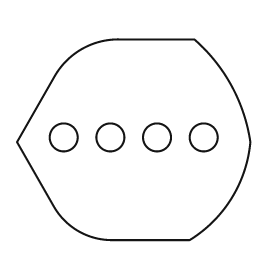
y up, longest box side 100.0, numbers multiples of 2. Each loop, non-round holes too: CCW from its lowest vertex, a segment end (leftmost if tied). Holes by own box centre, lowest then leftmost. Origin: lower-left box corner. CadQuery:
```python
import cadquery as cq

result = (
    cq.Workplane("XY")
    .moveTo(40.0, 0.0)
    .lineTo(74.0, 0.0)
    .threePointArc((92.0, 18.0), (100.0, 42.0))
    .threePointArc((92.0, 66.0), (76.0, 86.0))
    .lineTo(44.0, 86.0)
    .threePointArc((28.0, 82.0), (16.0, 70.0))
    .lineTo(0.0, 42.0)
    .lineTo(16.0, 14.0)
    .threePointArc((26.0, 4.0), (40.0, 0.0))
    .close()
    .moveTo(20.0, 44.0)
    .circle(6.0)
    .moveTo(40.0, 44.0)
    .circle(6.0)
    .moveTo(60.0, 44.0)
    .circle(6.0)
    .moveTo(80.0, 44.0)
    .circle(6.0)
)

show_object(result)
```